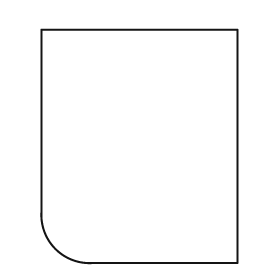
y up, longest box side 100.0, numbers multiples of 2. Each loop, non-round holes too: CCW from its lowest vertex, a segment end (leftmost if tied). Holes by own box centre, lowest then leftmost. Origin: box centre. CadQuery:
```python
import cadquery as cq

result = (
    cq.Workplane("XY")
    .moveTo(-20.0, -50.0)
    .lineTo(42.0, -50.0)
    .lineTo(42.0, 50.0)
    .lineTo(-42.0, 50.0)
    .lineTo(-42.0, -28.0)
    .threePointArc((-36.0, -44.0), (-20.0, -50.0))
    .close()
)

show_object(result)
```